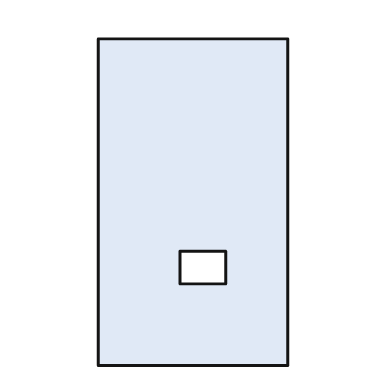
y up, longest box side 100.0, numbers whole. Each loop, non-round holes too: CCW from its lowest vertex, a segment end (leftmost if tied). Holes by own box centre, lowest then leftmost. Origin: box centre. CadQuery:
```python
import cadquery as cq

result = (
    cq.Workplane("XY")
    .moveTo(-29.0, -50.0)
    .lineTo(29.0, -50.0)
    .lineTo(29.0, 50.0)
    .lineTo(-29.0, 50.0)
    .close()
    .moveTo(-4.0, -25.0)
    .lineTo(10.0, -25.0)
    .lineTo(10.0, -15.0)
    .lineTo(-4.0, -15.0)
    .close()
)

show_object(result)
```